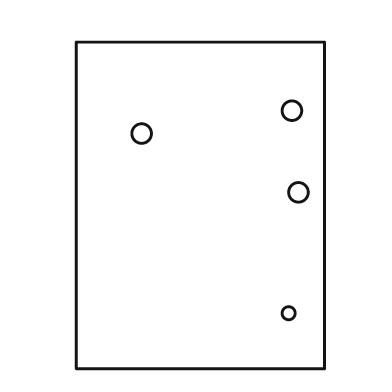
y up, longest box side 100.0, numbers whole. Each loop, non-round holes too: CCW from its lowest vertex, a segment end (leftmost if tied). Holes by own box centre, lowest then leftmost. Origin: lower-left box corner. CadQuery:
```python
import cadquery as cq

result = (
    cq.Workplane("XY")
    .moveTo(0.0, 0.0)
    .lineTo(76.0, 0.0)
    .lineTo(76.0, 100.0)
    .lineTo(0.0, 100.0)
    .close()
    .moveTo(65.0, 17.0)
    .circle(2.0)
    .moveTo(68.0, 54.0)
    .circle(3.0)
    .moveTo(20.0, 72.0)
    .circle(3.0)
    .moveTo(66.0, 79.0)
    .circle(3.0)
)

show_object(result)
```